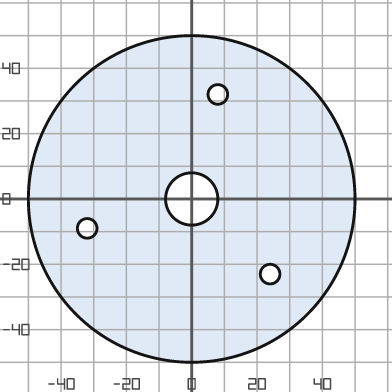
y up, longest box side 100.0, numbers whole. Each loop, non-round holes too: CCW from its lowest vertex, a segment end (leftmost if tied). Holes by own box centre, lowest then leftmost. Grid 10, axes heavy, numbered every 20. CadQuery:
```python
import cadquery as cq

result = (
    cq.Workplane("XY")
    .moveTo(0.0, 0.0)
    .circle(50.0)
    .moveTo(24.0, -23.0)
    .circle(3.0)
    .moveTo(-32.0, -9.0)
    .circle(3.0)
    .moveTo(0.0, 0.0)
    .circle(8.0)
    .moveTo(8.0, 32.0)
    .circle(3.0)
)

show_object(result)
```